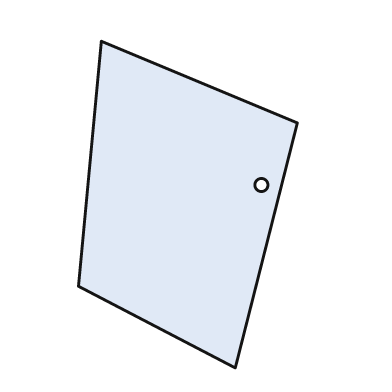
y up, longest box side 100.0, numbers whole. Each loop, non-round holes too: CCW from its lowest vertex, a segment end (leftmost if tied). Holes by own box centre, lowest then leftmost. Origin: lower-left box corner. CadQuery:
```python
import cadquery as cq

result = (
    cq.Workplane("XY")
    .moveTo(48.0, 0.0)
    .lineTo(67.0, 75.0)
    .lineTo(7.0, 100.0)
    .lineTo(0.0, 25.0)
    .close()
    .moveTo(56.0, 56.0)
    .circle(2.0)
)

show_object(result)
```